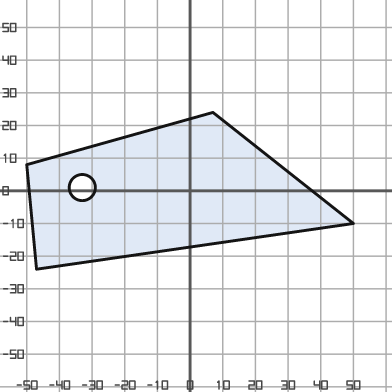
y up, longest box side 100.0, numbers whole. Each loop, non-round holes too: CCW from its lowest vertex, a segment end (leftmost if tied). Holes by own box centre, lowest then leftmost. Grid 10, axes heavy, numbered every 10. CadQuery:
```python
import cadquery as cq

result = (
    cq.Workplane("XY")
    .moveTo(-47.0, -24.0)
    .lineTo(50.0, -10.0)
    .lineTo(7.0, 24.0)
    .lineTo(-50.0, 8.0)
    .close()
    .moveTo(-33.0, 1.0)
    .circle(4.0)
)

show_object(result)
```